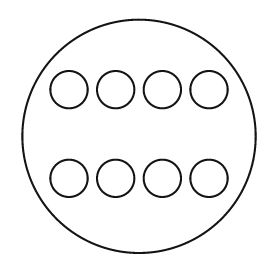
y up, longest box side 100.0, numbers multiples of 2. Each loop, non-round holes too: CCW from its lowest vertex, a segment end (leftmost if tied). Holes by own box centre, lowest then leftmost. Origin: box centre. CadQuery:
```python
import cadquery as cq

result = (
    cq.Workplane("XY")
    .moveTo(0.0, 0.0)
    .circle(50.0)
    .moveTo(-30.0, -18.0)
    .circle(8.0)
    .moveTo(-10.0, -18.0)
    .circle(8.0)
    .moveTo(10.0, -18.0)
    .circle(8.0)
    .moveTo(30.0, -18.0)
    .circle(8.0)
    .moveTo(-30.0, 20.0)
    .circle(8.0)
    .moveTo(-10.0, 20.0)
    .circle(8.0)
    .moveTo(10.0, 20.0)
    .circle(8.0)
    .moveTo(30.0, 20.0)
    .circle(8.0)
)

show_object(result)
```